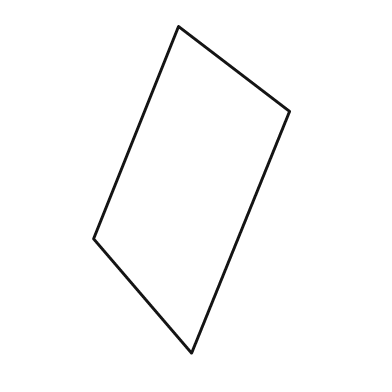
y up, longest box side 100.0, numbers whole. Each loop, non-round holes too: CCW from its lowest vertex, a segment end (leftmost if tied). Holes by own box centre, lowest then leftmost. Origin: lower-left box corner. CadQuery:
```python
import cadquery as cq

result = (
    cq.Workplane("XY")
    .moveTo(30.0, 0.0)
    .lineTo(60.0, 74.0)
    .lineTo(26.0, 100.0)
    .lineTo(0.0, 35.0)
    .close()
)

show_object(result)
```